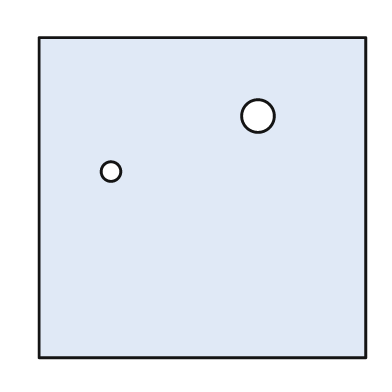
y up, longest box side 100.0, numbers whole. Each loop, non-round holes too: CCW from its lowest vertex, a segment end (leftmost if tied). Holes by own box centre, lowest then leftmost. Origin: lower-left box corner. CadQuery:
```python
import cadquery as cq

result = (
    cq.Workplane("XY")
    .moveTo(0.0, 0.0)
    .lineTo(100.0, 0.0)
    .lineTo(100.0, 98.0)
    .lineTo(0.0, 98.0)
    .close()
    .moveTo(22.0, 57.0)
    .circle(3.0)
    .moveTo(67.0, 74.0)
    .circle(5.0)
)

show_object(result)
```